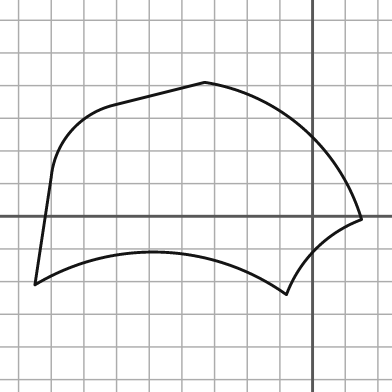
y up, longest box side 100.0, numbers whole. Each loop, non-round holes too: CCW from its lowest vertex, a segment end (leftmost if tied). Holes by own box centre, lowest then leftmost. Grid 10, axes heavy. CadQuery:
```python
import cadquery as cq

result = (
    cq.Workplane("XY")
    .moveTo(-8.0, -24.0)
    .threePointArc((1.0, -10.0), (15.0, -1.0))
    .threePointArc((-3.0, 27.0), (-33.0, 41.0))
    .lineTo(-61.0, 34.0)
    .threePointArc((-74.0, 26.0), (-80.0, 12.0))
    .lineTo(-85.0, -21.0)
    .threePointArc((-46.0, -11.0), (-8.0, -24.0))
    .close()
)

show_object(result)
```